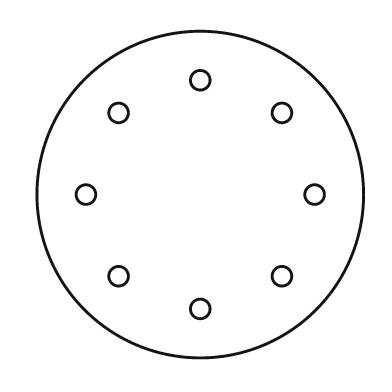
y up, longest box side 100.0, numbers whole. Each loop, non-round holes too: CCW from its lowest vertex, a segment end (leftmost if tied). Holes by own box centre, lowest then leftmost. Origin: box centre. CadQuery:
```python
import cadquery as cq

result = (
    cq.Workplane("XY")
    .moveTo(0.0, 0.0)
    .circle(50.0)
    .moveTo(0.0, -35.0)
    .circle(3.0)
    .moveTo(-25.0, -25.0)
    .circle(3.0)
    .moveTo(25.0, -25.0)
    .circle(3.0)
    .moveTo(-35.0, 0.0)
    .circle(3.0)
    .moveTo(35.0, 0.0)
    .circle(3.0)
    .moveTo(-25.0, 25.0)
    .circle(3.0)
    .moveTo(25.0, 25.0)
    .circle(3.0)
    .moveTo(0.0, 35.0)
    .circle(3.0)
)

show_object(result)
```